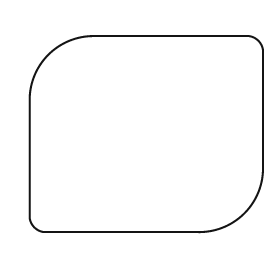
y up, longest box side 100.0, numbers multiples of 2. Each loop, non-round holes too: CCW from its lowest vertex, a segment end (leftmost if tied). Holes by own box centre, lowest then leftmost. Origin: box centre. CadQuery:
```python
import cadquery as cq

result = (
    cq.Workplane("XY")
    .moveTo(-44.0, -42.0)
    .lineTo(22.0, -42.0)
    .threePointArc((42.0, -34.0), (50.0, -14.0))
    .lineTo(50.0, 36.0)
    .threePointArc((48.0, 40.0), (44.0, 42.0))
    .lineTo(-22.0, 42.0)
    .threePointArc((-42.0, 34.0), (-50.0, 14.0))
    .lineTo(-50.0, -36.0)
    .threePointArc((-48.0, -40.0), (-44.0, -42.0))
    .close()
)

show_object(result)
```